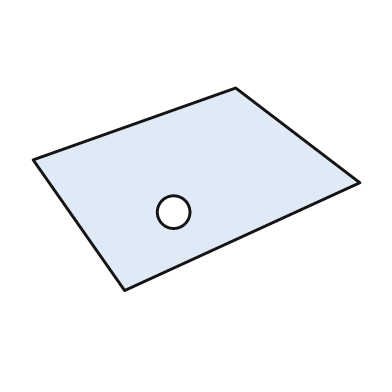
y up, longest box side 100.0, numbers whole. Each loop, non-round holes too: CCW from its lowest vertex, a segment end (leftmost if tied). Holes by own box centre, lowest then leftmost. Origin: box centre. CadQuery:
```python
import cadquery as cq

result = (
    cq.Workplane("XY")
    .moveTo(-22.0, -31.0)
    .lineTo(50.0, 2.0)
    .lineTo(12.0, 31.0)
    .lineTo(-50.0, 9.0)
    .close()
    .moveTo(-7.0, -7.0)
    .circle(5.0)
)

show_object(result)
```